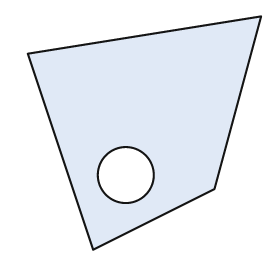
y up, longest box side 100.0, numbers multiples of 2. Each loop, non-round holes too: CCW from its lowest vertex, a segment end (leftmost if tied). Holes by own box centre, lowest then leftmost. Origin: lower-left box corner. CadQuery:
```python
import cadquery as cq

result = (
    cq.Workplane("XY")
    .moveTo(28.0, 0.0)
    .lineTo(80.0, 26.0)
    .lineTo(100.0, 100.0)
    .lineTo(0.0, 84.0)
    .close()
    .moveTo(42.0, 32.0)
    .circle(12.0)
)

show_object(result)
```